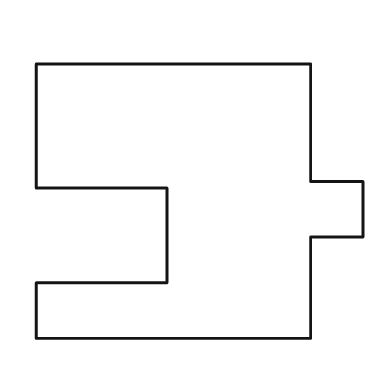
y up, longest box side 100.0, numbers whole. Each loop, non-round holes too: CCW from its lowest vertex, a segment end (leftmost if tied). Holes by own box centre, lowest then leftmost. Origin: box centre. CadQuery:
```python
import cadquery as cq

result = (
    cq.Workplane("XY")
    .moveTo(-50.0, -42.0)
    .lineTo(34.0, -42.0)
    .lineTo(34.0, -11.0)
    .lineTo(50.0, -11.0)
    .lineTo(50.0, 6.0)
    .lineTo(34.0, 6.0)
    .lineTo(34.0, 42.0)
    .lineTo(-50.0, 42.0)
    .lineTo(-50.0, 4.0)
    .lineTo(-10.0, 4.0)
    .lineTo(-10.0, -25.0)
    .lineTo(-50.0, -25.0)
    .close()
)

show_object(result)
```